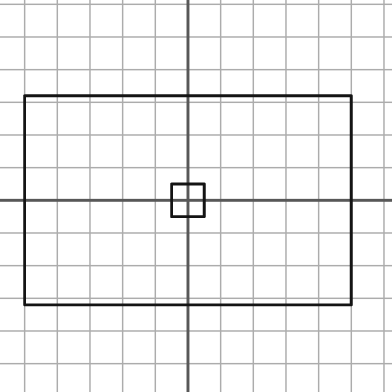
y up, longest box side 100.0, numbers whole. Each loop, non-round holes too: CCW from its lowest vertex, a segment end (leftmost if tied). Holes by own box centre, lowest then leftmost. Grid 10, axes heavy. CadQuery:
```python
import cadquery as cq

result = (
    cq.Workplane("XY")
    .moveTo(-50.0, -32.0)
    .lineTo(50.0, -32.0)
    .lineTo(50.0, 32.0)
    .lineTo(-50.0, 32.0)
    .close()
    .moveTo(-5.0, -5.0)
    .lineTo(5.0, -5.0)
    .lineTo(5.0, 5.0)
    .lineTo(-5.0, 5.0)
    .close()
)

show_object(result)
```